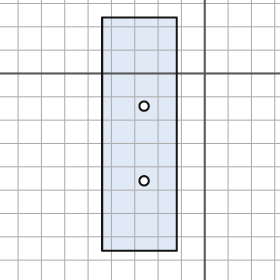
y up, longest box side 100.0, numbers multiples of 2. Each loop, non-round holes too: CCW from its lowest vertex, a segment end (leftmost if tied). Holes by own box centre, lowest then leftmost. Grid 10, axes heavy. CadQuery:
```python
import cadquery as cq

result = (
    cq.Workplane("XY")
    .moveTo(-44.0, -76.0)
    .lineTo(-12.0, -76.0)
    .lineTo(-12.0, 24.0)
    .lineTo(-44.0, 24.0)
    .close()
    .moveTo(-26.0, -46.0)
    .circle(2.0)
    .moveTo(-26.0, -14.0)
    .circle(2.0)
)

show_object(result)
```